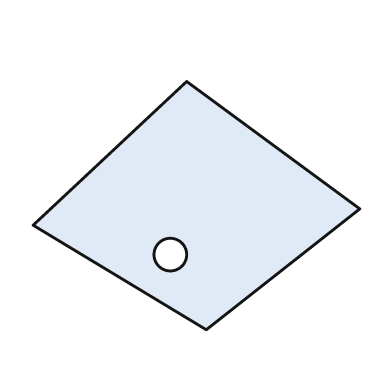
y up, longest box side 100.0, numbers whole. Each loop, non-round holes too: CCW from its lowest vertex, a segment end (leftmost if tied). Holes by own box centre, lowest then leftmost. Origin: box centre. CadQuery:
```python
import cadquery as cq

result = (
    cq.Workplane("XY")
    .moveTo(3.0, -38.0)
    .lineTo(50.0, -1.0)
    .lineTo(-3.0, 38.0)
    .lineTo(-50.0, -6.0)
    .close()
    .moveTo(-8.0, -15.0)
    .circle(5.0)
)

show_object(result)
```